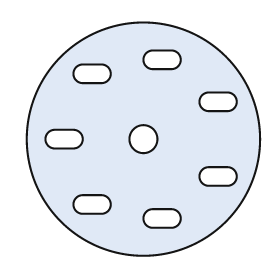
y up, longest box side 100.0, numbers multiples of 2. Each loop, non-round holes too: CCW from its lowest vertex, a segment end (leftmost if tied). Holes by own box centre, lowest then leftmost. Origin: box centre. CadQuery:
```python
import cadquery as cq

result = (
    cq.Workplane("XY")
    .moveTo(0.0, 0.0)
    .circle(50.0)
    .moveTo(4.0, -38.0)
    .lineTo(12.0, -38.0)
    .threePointArc((16.0, -34.0), (12.0, -30.0))
    .lineTo(4.0, -30.0)
    .threePointArc((0.0, -34.0), (4.0, -38.0))
    .close()
    .moveTo(-26.0, -32.0)
    .lineTo(-18.0, -32.0)
    .threePointArc((-14.0, -28.0), (-18.0, -24.0))
    .lineTo(-26.0, -24.0)
    .threePointArc((-30.0, -28.0), (-26.0, -32.0))
    .close()
    .moveTo(28.0, -20.0)
    .lineTo(36.0, -20.0)
    .threePointArc((40.0, -16.0), (36.0, -12.0))
    .lineTo(28.0, -12.0)
    .threePointArc((24.0, -16.0), (28.0, -20.0))
    .close()
    .moveTo(-38.0, -4.0)
    .lineTo(-30.0, -4.0)
    .threePointArc((-26.0, 0.0), (-30.0, 4.0))
    .lineTo(-38.0, 4.0)
    .threePointArc((-42.0, 0.0), (-38.0, -4.0))
    .close()
    .moveTo(0.0, 0.0)
    .circle(6.0)
    .moveTo(28.0, 12.0)
    .lineTo(36.0, 12.0)
    .threePointArc((40.0, 16.0), (36.0, 20.0))
    .lineTo(28.0, 20.0)
    .threePointArc((24.0, 16.0), (28.0, 12.0))
    .close()
    .moveTo(-26.0, 24.0)
    .lineTo(-18.0, 24.0)
    .threePointArc((-14.0, 28.0), (-18.0, 32.0))
    .lineTo(-26.0, 32.0)
    .threePointArc((-30.0, 28.0), (-26.0, 24.0))
    .close()
    .moveTo(4.0, 30.0)
    .lineTo(12.0, 30.0)
    .threePointArc((16.0, 34.0), (12.0, 38.0))
    .lineTo(4.0, 38.0)
    .threePointArc((0.0, 34.0), (4.0, 30.0))
    .close()
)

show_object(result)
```